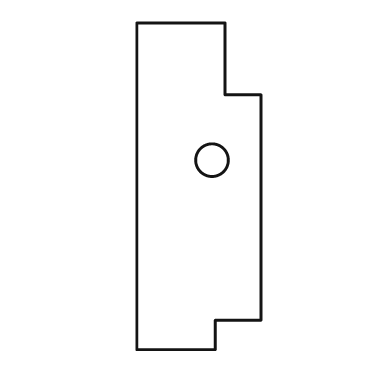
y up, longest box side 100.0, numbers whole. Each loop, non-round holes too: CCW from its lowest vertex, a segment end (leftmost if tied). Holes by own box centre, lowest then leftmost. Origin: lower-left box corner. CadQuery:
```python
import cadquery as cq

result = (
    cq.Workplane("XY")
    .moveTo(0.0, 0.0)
    .lineTo(24.0, 0.0)
    .lineTo(24.0, 9.0)
    .lineTo(38.0, 9.0)
    .lineTo(38.0, 78.0)
    .lineTo(27.0, 78.0)
    .lineTo(27.0, 100.0)
    .lineTo(0.0, 100.0)
    .close()
    .moveTo(23.0, 58.0)
    .circle(5.0)
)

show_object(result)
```